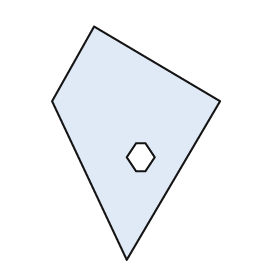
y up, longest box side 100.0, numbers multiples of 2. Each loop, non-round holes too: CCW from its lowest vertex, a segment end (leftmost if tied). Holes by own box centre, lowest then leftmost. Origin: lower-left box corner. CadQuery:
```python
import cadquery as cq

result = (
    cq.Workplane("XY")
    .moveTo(32.0, 0.0)
    .lineTo(72.0, 68.0)
    .lineTo(18.0, 100.0)
    .lineTo(0.0, 68.0)
    .close()
    .moveTo(36.0, 38.0)
    .lineTo(40.0, 38.0)
    .lineTo(44.0, 44.0)
    .lineTo(40.0, 50.0)
    .lineTo(36.0, 50.0)
    .lineTo(32.0, 44.0)
    .close()
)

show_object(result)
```